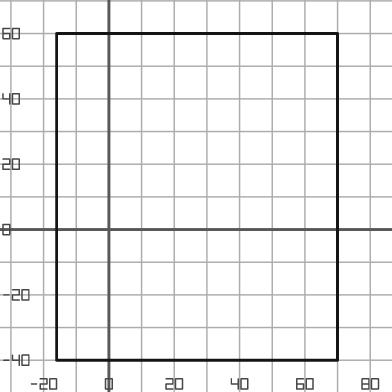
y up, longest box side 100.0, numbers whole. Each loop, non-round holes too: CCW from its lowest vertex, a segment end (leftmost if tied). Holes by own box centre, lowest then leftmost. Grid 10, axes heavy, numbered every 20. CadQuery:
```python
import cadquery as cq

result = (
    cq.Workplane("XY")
    .moveTo(-16.0, -40.0)
    .lineTo(70.0, -40.0)
    .lineTo(70.0, 60.0)
    .lineTo(-16.0, 60.0)
    .close()
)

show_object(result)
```